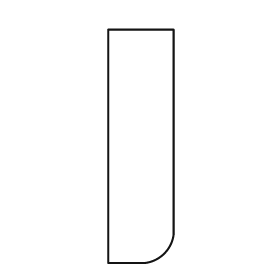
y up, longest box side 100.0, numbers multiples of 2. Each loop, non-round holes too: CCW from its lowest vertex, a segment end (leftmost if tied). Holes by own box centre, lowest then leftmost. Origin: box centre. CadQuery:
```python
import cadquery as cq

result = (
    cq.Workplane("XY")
    .moveTo(-14.0, -50.0)
    .lineTo(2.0, -50.0)
    .threePointArc((10.0, -46.0), (14.0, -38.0))
    .lineTo(14.0, 50.0)
    .lineTo(-14.0, 50.0)
    .close()
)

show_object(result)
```